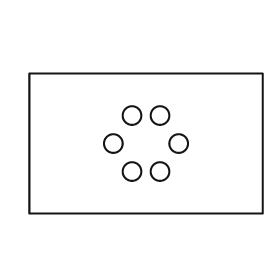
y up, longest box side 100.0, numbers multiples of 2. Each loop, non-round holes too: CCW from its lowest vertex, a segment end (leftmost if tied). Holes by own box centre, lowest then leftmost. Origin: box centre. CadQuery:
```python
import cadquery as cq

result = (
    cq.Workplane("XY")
    .moveTo(-50.0, -30.0)
    .lineTo(50.0, -30.0)
    .lineTo(50.0, 30.0)
    .lineTo(-50.0, 30.0)
    .close()
    .moveTo(-6.0, -12.0)
    .circle(4.0)
    .moveTo(6.0, -12.0)
    .circle(4.0)
    .moveTo(-14.0, 0.0)
    .circle(4.0)
    .moveTo(14.0, 0.0)
    .circle(4.0)
    .moveTo(-6.0, 12.0)
    .circle(4.0)
    .moveTo(6.0, 12.0)
    .circle(4.0)
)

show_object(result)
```